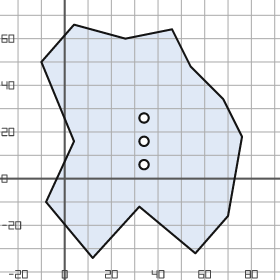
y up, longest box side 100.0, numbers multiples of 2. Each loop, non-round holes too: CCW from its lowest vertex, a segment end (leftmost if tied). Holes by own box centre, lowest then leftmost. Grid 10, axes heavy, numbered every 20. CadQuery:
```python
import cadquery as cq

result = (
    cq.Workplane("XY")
    .moveTo(12.0, -34.0)
    .lineTo(32.0, -12.0)
    .lineTo(56.0, -32.0)
    .lineTo(70.0, -16.0)
    .lineTo(76.0, 18.0)
    .lineTo(68.0, 34.0)
    .lineTo(54.0, 48.0)
    .lineTo(46.0, 64.0)
    .lineTo(26.0, 60.0)
    .lineTo(4.0, 66.0)
    .lineTo(-10.0, 50.0)
    .lineTo(4.0, 16.0)
    .lineTo(-8.0, -10.0)
    .close()
    .moveTo(34.0, 6.0)
    .circle(2.0)
    .moveTo(34.0, 16.0)
    .circle(2.0)
    .moveTo(34.0, 26.0)
    .circle(2.0)
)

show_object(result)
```